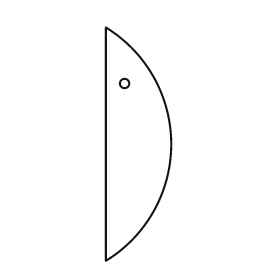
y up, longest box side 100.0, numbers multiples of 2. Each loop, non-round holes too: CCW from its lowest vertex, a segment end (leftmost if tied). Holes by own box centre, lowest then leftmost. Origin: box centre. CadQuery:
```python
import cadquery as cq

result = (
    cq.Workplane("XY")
    .moveTo(-14.0, -50.0)
    .threePointArc((14.0, 0.0), (-14.0, 50.0))
    .close()
    .moveTo(-6.0, 26.0)
    .circle(2.0)
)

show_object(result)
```